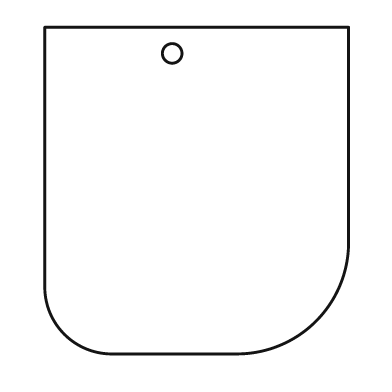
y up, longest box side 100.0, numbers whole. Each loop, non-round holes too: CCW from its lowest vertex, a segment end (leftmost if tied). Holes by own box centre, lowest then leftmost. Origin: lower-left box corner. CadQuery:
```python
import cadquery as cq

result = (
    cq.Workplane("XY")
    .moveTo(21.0, 0.0)
    .lineTo(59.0, 0.0)
    .threePointArc((83.0, 10.0), (93.0, 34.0))
    .lineTo(93.0, 100.0)
    .lineTo(0.0, 100.0)
    .lineTo(0.0, 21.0)
    .threePointArc((6.0, 6.0), (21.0, 0.0))
    .close()
    .moveTo(39.0, 92.0)
    .circle(3.0)
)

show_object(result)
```